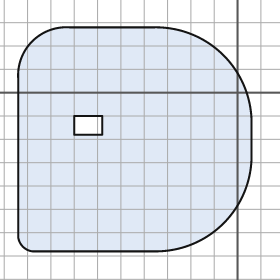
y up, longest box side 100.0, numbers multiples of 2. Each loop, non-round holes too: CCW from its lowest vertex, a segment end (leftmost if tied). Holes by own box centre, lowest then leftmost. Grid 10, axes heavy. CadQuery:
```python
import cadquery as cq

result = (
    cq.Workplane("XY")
    .moveTo(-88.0, -68.0)
    .lineTo(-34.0, -68.0)
    .threePointArc((-6.0, -56.0), (6.0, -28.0))
    .lineTo(6.0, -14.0)
    .threePointArc((-6.0, 16.0), (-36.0, 28.0))
    .lineTo(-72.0, 28.0)
    .threePointArc((-88.0, 22.0), (-94.0, 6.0))
    .lineTo(-94.0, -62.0)
    .threePointArc((-92.0, -66.0), (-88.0, -68.0))
    .close()
    .moveTo(-70.0, -18.0)
    .lineTo(-58.0, -18.0)
    .lineTo(-58.0, -10.0)
    .lineTo(-70.0, -10.0)
    .close()
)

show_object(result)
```